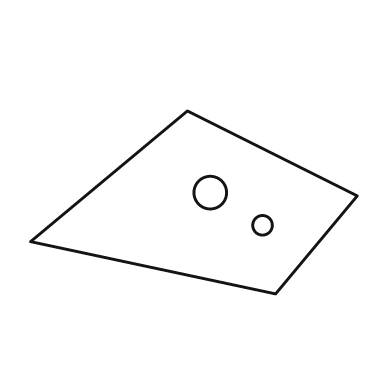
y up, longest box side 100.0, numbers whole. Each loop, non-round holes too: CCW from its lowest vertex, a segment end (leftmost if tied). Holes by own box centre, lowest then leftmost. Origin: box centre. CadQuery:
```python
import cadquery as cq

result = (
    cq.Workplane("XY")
    .moveTo(25.0, -28.0)
    .lineTo(50.0, 2.0)
    .lineTo(-2.0, 28.0)
    .lineTo(-50.0, -12.0)
    .close()
    .moveTo(21.0, -7.0)
    .circle(3.0)
    .moveTo(5.0, 3.0)
    .circle(5.0)
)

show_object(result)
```